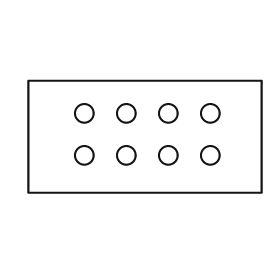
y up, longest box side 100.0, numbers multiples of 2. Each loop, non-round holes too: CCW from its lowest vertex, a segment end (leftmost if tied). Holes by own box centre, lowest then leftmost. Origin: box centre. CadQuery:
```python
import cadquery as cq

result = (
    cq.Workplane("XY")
    .moveTo(-50.0, -24.0)
    .lineTo(50.0, -24.0)
    .lineTo(50.0, 24.0)
    .lineTo(-50.0, 24.0)
    .close()
    .moveTo(-26.0, -8.0)
    .circle(4.0)
    .moveTo(-8.0, -8.0)
    .circle(4.0)
    .moveTo(10.0, -8.0)
    .circle(4.0)
    .moveTo(28.0, -8.0)
    .circle(4.0)
    .moveTo(-26.0, 10.0)
    .circle(4.0)
    .moveTo(-8.0, 10.0)
    .circle(4.0)
    .moveTo(10.0, 10.0)
    .circle(4.0)
    .moveTo(28.0, 10.0)
    .circle(4.0)
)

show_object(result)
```